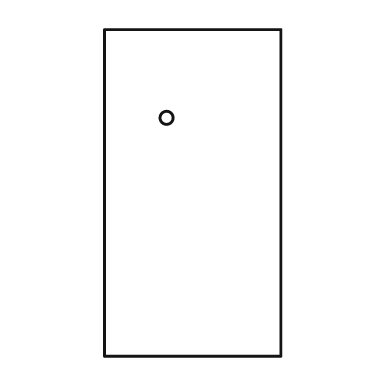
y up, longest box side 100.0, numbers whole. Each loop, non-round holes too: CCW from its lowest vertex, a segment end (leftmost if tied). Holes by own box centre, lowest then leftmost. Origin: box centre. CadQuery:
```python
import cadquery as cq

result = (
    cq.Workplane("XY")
    .moveTo(-27.0, -50.0)
    .lineTo(27.0, -50.0)
    .lineTo(27.0, 50.0)
    .lineTo(-27.0, 50.0)
    .close()
    .moveTo(-8.0, 23.0)
    .circle(2.0)
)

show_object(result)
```